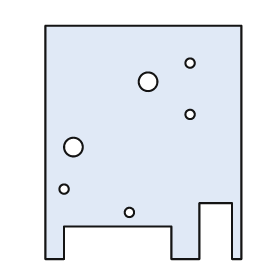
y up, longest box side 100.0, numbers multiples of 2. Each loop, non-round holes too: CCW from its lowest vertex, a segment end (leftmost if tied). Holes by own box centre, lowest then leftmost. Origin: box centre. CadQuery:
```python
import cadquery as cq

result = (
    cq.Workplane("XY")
    .moveTo(-42.0, -50.0)
    .lineTo(-34.0, -50.0)
    .lineTo(-34.0, -36.0)
    .lineTo(12.0, -36.0)
    .lineTo(12.0, -50.0)
    .lineTo(24.0, -50.0)
    .lineTo(24.0, -26.0)
    .lineTo(38.0, -26.0)
    .lineTo(38.0, -50.0)
    .lineTo(42.0, -50.0)
    .lineTo(42.0, 50.0)
    .lineTo(-42.0, 50.0)
    .close()
    .moveTo(-6.0, -30.0)
    .circle(2.0)
    .moveTo(-34.0, -20.0)
    .circle(2.0)
    .moveTo(-30.0, -2.0)
    .circle(4.0)
    .moveTo(20.0, 12.0)
    .circle(2.0)
    .moveTo(2.0, 26.0)
    .circle(4.0)
    .moveTo(20.0, 34.0)
    .circle(2.0)
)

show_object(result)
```